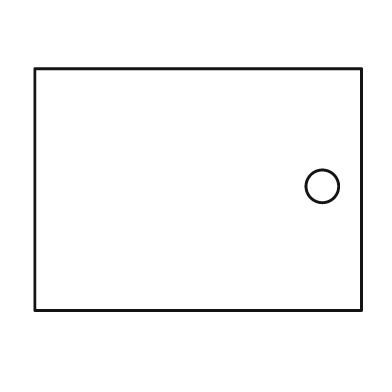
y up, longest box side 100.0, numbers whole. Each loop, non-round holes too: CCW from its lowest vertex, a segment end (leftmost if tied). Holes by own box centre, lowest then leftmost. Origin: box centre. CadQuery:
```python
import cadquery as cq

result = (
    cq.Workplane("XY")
    .moveTo(-50.0, -37.0)
    .lineTo(50.0, -37.0)
    .lineTo(50.0, 37.0)
    .lineTo(-50.0, 37.0)
    .close()
    .moveTo(38.0, 1.0)
    .circle(5.0)
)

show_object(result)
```